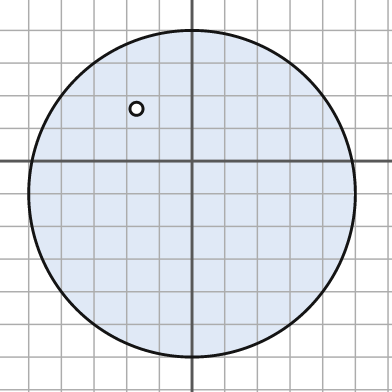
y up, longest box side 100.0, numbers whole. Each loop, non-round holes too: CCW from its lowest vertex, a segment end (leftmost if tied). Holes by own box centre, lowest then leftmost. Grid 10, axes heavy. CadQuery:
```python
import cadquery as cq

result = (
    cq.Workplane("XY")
    .moveTo(0.0, -10.0)
    .circle(50.0)
    .moveTo(-17.0, 16.0)
    .circle(2.0)
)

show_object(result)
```